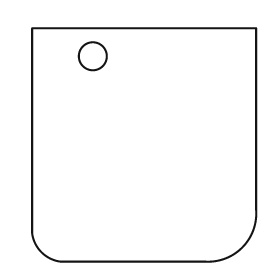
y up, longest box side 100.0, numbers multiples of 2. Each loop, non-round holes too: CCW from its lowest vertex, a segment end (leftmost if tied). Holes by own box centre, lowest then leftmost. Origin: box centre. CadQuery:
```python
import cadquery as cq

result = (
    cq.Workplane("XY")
    .moveTo(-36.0, -50.0)
    .lineTo(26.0, -50.0)
    .threePointArc((42.0, -44.0), (48.0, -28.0))
    .lineTo(48.0, 50.0)
    .lineTo(-48.0, 50.0)
    .lineTo(-48.0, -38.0)
    .threePointArc((-44.0, -46.0), (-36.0, -50.0))
    .close()
    .moveTo(-22.0, 38.0)
    .circle(6.0)
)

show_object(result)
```